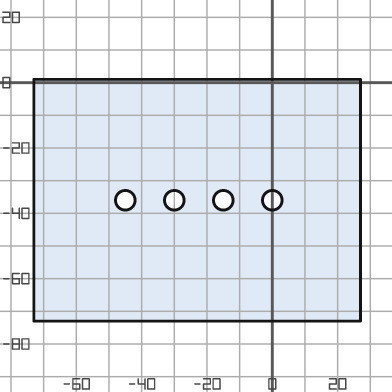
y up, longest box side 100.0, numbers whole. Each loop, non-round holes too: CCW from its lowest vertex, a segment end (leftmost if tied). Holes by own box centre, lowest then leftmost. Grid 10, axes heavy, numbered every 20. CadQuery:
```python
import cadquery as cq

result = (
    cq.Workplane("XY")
    .moveTo(-73.0, -73.0)
    .lineTo(27.0, -73.0)
    .lineTo(27.0, 1.0)
    .lineTo(-73.0, 1.0)
    .close()
    .moveTo(-45.0, -36.0)
    .circle(3.0)
    .moveTo(-30.0, -36.0)
    .circle(3.0)
    .moveTo(-15.0, -36.0)
    .circle(3.0)
    .moveTo(0.0, -36.0)
    .circle(3.0)
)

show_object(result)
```